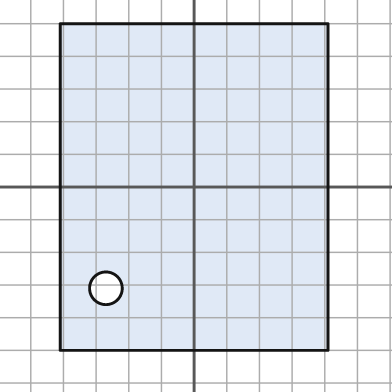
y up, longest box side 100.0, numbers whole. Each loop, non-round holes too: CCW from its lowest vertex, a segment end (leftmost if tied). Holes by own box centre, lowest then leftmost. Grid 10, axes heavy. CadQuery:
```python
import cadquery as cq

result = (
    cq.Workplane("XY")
    .moveTo(-41.0, -50.0)
    .lineTo(41.0, -50.0)
    .lineTo(41.0, 50.0)
    .lineTo(-41.0, 50.0)
    .close()
    .moveTo(-27.0, -31.0)
    .circle(5.0)
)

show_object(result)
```